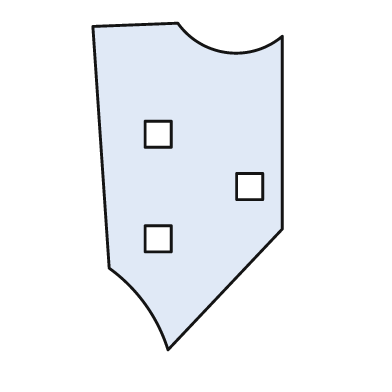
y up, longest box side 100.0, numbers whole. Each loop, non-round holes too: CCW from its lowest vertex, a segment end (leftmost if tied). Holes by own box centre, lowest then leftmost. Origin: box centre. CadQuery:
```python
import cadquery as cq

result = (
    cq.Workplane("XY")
    .moveTo(-6.0, -50.0)
    .lineTo(29.0, -13.0)
    .lineTo(29.0, 46.0)
    .threePointArc((12.0, 41.0), (-3.0, 50.0))
    .lineTo(-29.0, 49.0)
    .lineTo(-24.0, -25.0)
    .threePointArc((-13.0, -36.0), (-6.0, -50.0))
    .close()
    .moveTo(-13.0, -20.0)
    .lineTo(-5.0, -20.0)
    .lineTo(-5.0, -12.0)
    .lineTo(-13.0, -12.0)
    .close()
    .moveTo(15.0, -4.0)
    .lineTo(23.0, -4.0)
    .lineTo(23.0, 4.0)
    .lineTo(15.0, 4.0)
    .close()
    .moveTo(-13.0, 12.0)
    .lineTo(-5.0, 12.0)
    .lineTo(-5.0, 20.0)
    .lineTo(-13.0, 20.0)
    .close()
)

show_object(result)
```